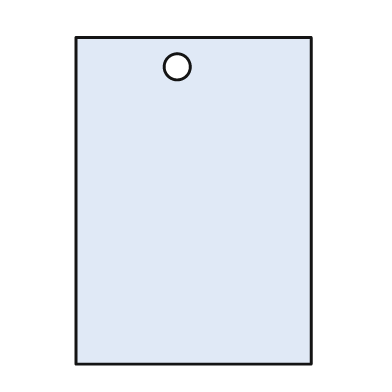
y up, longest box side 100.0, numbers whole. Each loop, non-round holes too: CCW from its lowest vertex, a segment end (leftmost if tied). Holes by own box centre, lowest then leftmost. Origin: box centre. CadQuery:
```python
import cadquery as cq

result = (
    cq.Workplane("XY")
    .moveTo(-36.0, -50.0)
    .lineTo(36.0, -50.0)
    .lineTo(36.0, 50.0)
    .lineTo(-36.0, 50.0)
    .close()
    .moveTo(-5.0, 41.0)
    .circle(4.0)
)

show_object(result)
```